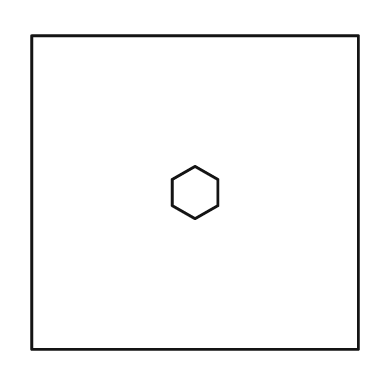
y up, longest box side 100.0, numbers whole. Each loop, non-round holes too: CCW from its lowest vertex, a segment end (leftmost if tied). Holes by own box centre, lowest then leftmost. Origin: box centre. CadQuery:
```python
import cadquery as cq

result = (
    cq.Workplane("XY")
    .moveTo(-50.0, -48.0)
    .lineTo(50.0, -48.0)
    .lineTo(50.0, 48.0)
    .lineTo(-50.0, 48.0)
    .close()
    .moveTo(0.0, -8.0)
    .lineTo(7.0, -4.0)
    .lineTo(7.0, 4.0)
    .lineTo(0.0, 8.0)
    .lineTo(-7.0, 4.0)
    .lineTo(-7.0, -4.0)
    .close()
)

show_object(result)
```